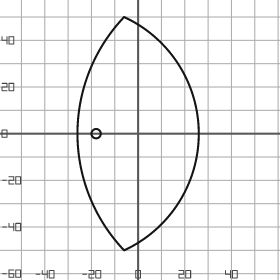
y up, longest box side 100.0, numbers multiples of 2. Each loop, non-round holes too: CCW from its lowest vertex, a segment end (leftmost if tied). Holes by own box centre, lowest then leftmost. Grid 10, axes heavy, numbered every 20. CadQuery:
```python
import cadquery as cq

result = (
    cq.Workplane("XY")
    .moveTo(-6.0, -50.0)
    .threePointArc((26.0, 0.0), (-6.0, 50.0))
    .threePointArc((-26.0, 0.0), (-6.0, -50.0))
    .close()
    .moveTo(-18.0, 0.0)
    .circle(2.0)
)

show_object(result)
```